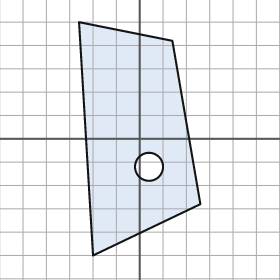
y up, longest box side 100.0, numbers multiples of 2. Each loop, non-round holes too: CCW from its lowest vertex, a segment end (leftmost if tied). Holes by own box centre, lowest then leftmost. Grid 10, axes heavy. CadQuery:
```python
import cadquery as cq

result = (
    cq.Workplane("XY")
    .moveTo(-20.0, -50.0)
    .lineTo(26.0, -28.0)
    .lineTo(14.0, 42.0)
    .lineTo(-26.0, 50.0)
    .close()
    .moveTo(4.0, -12.0)
    .circle(6.0)
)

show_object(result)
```